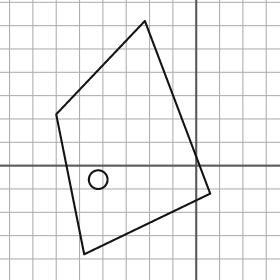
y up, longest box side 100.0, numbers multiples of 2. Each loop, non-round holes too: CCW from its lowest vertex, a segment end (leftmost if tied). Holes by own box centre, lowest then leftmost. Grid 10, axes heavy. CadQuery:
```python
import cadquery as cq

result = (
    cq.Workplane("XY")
    .moveTo(-48.0, -38.0)
    .lineTo(6.0, -12.0)
    .lineTo(-22.0, 62.0)
    .lineTo(-60.0, 22.0)
    .close()
    .moveTo(-42.0, -6.0)
    .circle(4.0)
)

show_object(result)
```